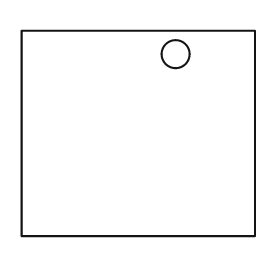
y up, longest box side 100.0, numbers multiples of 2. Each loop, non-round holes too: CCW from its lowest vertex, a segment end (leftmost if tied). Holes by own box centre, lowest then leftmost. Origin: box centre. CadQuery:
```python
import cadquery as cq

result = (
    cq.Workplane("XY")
    .moveTo(-50.0, -44.0)
    .lineTo(50.0, -44.0)
    .lineTo(50.0, 44.0)
    .lineTo(-50.0, 44.0)
    .close()
    .moveTo(16.0, 34.0)
    .circle(6.0)
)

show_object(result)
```